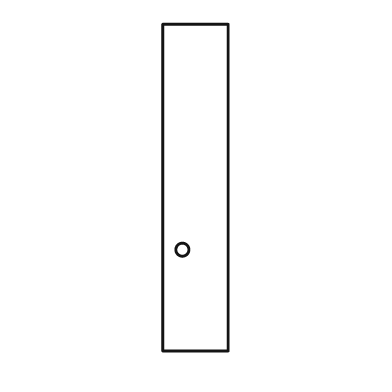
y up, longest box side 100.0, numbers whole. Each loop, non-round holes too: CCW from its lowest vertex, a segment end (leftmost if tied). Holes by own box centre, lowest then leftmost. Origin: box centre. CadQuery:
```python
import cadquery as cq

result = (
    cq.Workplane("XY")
    .moveTo(-10.0, -50.0)
    .lineTo(10.0, -50.0)
    .lineTo(10.0, 50.0)
    .lineTo(-10.0, 50.0)
    .close()
    .moveTo(-4.0, -19.0)
    .circle(2.0)
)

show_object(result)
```